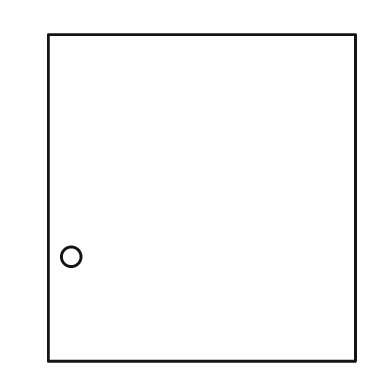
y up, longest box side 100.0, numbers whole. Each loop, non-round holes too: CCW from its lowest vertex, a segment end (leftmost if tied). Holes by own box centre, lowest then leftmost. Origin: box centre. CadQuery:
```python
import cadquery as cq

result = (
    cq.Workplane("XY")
    .moveTo(-47.0, -50.0)
    .lineTo(47.0, -50.0)
    .lineTo(47.0, 50.0)
    .lineTo(-47.0, 50.0)
    .close()
    .moveTo(-40.0, -18.0)
    .circle(3.0)
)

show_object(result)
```